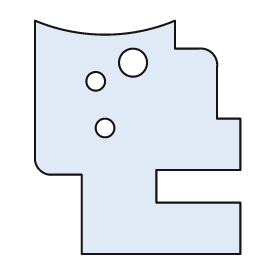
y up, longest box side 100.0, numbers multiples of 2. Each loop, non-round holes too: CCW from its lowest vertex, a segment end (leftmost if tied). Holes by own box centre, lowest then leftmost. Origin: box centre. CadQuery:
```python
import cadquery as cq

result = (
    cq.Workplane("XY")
    .moveTo(-24.0, -50.0)
    .lineTo(44.0, -50.0)
    .lineTo(44.0, -28.0)
    .lineTo(8.0, -28.0)
    .lineTo(8.0, -14.0)
    .lineTo(44.0, -14.0)
    .lineTo(44.0, 8.0)
    .lineTo(34.0, 8.0)
    .lineTo(34.0, 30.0)
    .threePointArc((32.0, 36.0), (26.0, 38.0))
    .lineTo(16.0, 38.0)
    .lineTo(16.0, 50.0)
    .threePointArc((-14.0, 44.0), (-44.0, 50.0))
    .lineTo(-44.0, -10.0)
    .threePointArc((-42.0, -14.0), (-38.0, -16.0))
    .lineTo(-24.0, -16.0)
    .close()
    .moveTo(-14.0, 4.0)
    .circle(4.0)
    .moveTo(-18.0, 24.0)
    .circle(4.0)
    .moveTo(-2.0, 32.0)
    .circle(6.0)
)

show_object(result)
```